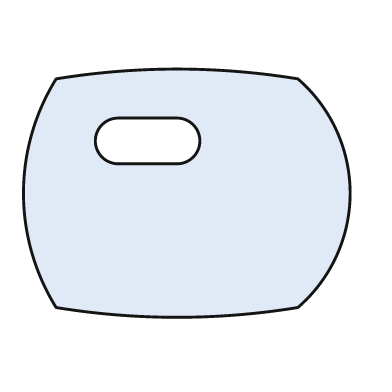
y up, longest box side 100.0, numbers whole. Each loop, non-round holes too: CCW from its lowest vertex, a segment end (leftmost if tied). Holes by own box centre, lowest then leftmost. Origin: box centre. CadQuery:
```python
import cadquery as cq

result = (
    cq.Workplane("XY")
    .moveTo(-40.0, -35.0)
    .threePointArc((-3.0, -38.0), (34.0, -35.0))
    .threePointArc((50.0, 0.0), (34.0, 35.0))
    .threePointArc((-3.0, 38.0), (-40.0, 35.0))
    .threePointArc((-50.0, 0.0), (-40.0, -35.0))
    .close()
    .moveTo(-21.0, 9.0)
    .lineTo(-3.0, 9.0)
    .threePointArc((4.0, 16.0), (-3.0, 23.0))
    .lineTo(-21.0, 23.0)
    .threePointArc((-28.0, 16.0), (-21.0, 9.0))
    .close()
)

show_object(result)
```